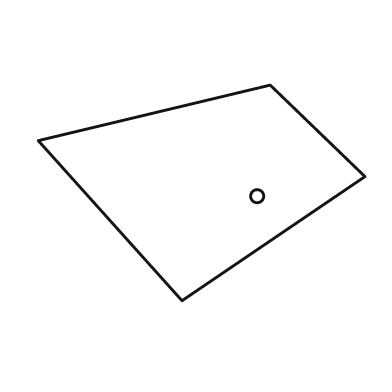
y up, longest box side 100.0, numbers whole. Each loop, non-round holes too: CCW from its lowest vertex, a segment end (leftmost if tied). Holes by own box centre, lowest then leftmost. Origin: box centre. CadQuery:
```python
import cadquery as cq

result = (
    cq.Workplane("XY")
    .moveTo(-6.0, -33.0)
    .lineTo(50.0, 5.0)
    .lineTo(21.0, 33.0)
    .lineTo(-50.0, 16.0)
    .close()
    .moveTo(17.0, -1.0)
    .circle(2.0)
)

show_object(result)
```